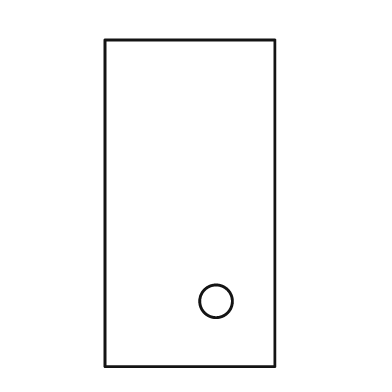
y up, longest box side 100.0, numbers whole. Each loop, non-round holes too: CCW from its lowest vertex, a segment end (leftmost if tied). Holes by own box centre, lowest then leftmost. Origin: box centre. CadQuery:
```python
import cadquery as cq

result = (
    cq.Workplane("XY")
    .moveTo(-26.0, -50.0)
    .lineTo(26.0, -50.0)
    .lineTo(26.0, 50.0)
    .lineTo(-26.0, 50.0)
    .close()
    .moveTo(8.0, -30.0)
    .circle(5.0)
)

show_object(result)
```